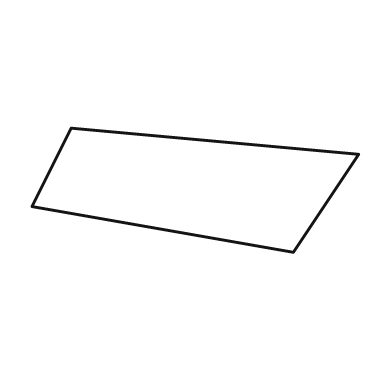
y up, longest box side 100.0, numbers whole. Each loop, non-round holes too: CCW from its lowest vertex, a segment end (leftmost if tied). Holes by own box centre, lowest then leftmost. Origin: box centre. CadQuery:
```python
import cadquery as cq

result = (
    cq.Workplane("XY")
    .moveTo(30.0, -19.0)
    .lineTo(50.0, 11.0)
    .lineTo(-38.0, 19.0)
    .lineTo(-50.0, -5.0)
    .close()
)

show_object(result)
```